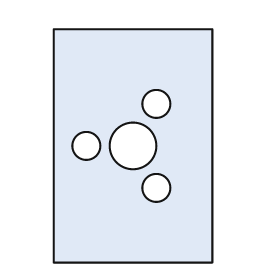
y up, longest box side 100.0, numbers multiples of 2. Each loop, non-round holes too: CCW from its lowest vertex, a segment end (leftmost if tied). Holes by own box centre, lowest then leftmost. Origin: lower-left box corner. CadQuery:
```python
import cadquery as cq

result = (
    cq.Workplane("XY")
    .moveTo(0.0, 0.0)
    .lineTo(68.0, 0.0)
    .lineTo(68.0, 100.0)
    .lineTo(0.0, 100.0)
    .close()
    .moveTo(44.0, 32.0)
    .circle(6.0)
    .moveTo(14.0, 50.0)
    .circle(6.0)
    .moveTo(34.0, 50.0)
    .circle(10.0)
    .moveTo(44.0, 68.0)
    .circle(6.0)
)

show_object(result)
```